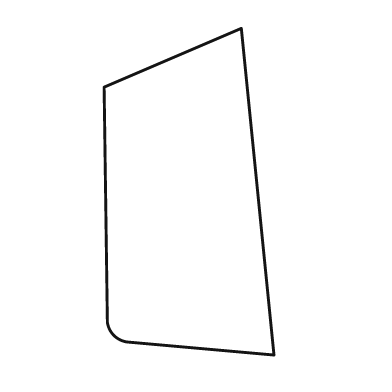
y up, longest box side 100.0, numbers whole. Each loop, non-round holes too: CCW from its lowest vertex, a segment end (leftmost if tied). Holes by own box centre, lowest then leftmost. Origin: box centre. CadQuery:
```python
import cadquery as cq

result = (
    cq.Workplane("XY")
    .moveTo(26.0, -50.0)
    .lineTo(16.0, 50.0)
    .lineTo(-26.0, 32.0)
    .lineTo(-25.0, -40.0)
    .threePointArc((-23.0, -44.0), (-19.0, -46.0))
    .close()
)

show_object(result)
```